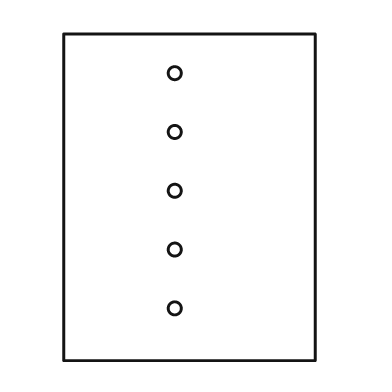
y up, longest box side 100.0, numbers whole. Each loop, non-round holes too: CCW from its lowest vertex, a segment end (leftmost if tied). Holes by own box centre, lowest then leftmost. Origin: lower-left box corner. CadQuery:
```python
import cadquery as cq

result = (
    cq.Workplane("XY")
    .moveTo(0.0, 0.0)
    .lineTo(77.0, 0.0)
    .lineTo(77.0, 100.0)
    .lineTo(0.0, 100.0)
    .close()
    .moveTo(34.0, 16.0)
    .circle(2.0)
    .moveTo(34.0, 34.0)
    .circle(2.0)
    .moveTo(34.0, 52.0)
    .circle(2.0)
    .moveTo(34.0, 70.0)
    .circle(2.0)
    .moveTo(34.0, 88.0)
    .circle(2.0)
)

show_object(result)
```